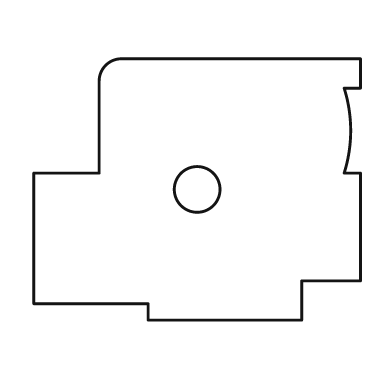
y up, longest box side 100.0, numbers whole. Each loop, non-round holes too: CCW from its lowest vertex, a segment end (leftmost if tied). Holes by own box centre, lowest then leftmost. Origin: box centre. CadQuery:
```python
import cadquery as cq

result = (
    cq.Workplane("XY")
    .moveTo(-15.0, -40.0)
    .lineTo(32.0, -40.0)
    .lineTo(32.0, -28.0)
    .lineTo(50.0, -28.0)
    .lineTo(50.0, 5.0)
    .lineTo(45.0, 5.0)
    .threePointArc((47.0, 18.0), (45.0, 31.0))
    .lineTo(50.0, 31.0)
    .lineTo(50.0, 40.0)
    .lineTo(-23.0, 40.0)
    .threePointArc((-28.0, 38.0), (-30.0, 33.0))
    .lineTo(-30.0, 5.0)
    .lineTo(-50.0, 5.0)
    .lineTo(-50.0, -35.0)
    .lineTo(-15.0, -35.0)
    .close()
    .moveTo(0.0, 0.0)
    .circle(7.0)
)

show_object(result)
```